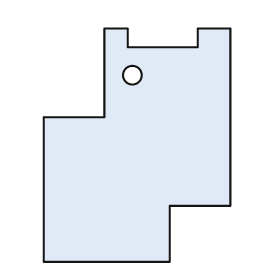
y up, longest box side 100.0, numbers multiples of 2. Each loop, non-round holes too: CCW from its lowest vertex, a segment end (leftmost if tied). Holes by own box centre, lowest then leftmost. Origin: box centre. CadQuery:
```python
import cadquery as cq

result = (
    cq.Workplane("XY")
    .moveTo(-40.0, -50.0)
    .lineTo(14.0, -50.0)
    .lineTo(14.0, -26.0)
    .lineTo(40.0, -26.0)
    .lineTo(40.0, 50.0)
    .lineTo(26.0, 50.0)
    .lineTo(26.0, 42.0)
    .lineTo(-4.0, 42.0)
    .lineTo(-4.0, 50.0)
    .lineTo(-14.0, 50.0)
    .lineTo(-14.0, 12.0)
    .lineTo(-40.0, 12.0)
    .close()
    .moveTo(-2.0, 30.0)
    .circle(4.0)
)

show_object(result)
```